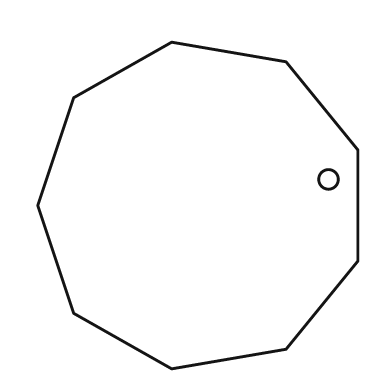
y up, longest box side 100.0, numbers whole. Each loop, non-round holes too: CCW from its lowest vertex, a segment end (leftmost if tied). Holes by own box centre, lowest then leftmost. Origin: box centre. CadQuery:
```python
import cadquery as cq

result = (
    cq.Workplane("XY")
    .moveTo(-8.0, -50.0)
    .lineTo(27.0, -44.0)
    .lineTo(49.0, -17.0)
    .lineTo(49.0, 17.0)
    .lineTo(27.0, 44.0)
    .lineTo(-8.0, 50.0)
    .lineTo(-38.0, 33.0)
    .lineTo(-49.0, 0.0)
    .lineTo(-38.0, -33.0)
    .close()
    .moveTo(40.0, 8.0)
    .circle(3.0)
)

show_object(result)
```